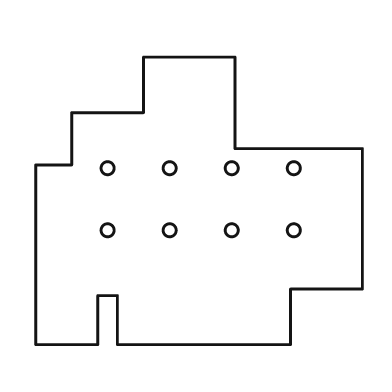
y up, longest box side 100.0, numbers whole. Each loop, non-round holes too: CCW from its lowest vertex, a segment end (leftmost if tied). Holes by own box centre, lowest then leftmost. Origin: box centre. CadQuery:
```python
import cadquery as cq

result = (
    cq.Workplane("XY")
    .moveTo(-50.0, -44.0)
    .lineTo(-31.0, -44.0)
    .lineTo(-31.0, -29.0)
    .lineTo(-25.0, -29.0)
    .lineTo(-25.0, -44.0)
    .lineTo(28.0, -44.0)
    .lineTo(28.0, -27.0)
    .lineTo(50.0, -27.0)
    .lineTo(50.0, 16.0)
    .lineTo(11.0, 16.0)
    .lineTo(11.0, 44.0)
    .lineTo(-17.0, 44.0)
    .lineTo(-17.0, 27.0)
    .lineTo(-39.0, 27.0)
    .lineTo(-39.0, 11.0)
    .lineTo(-50.0, 11.0)
    .close()
    .moveTo(-28.0, -9.0)
    .circle(2.0)
    .moveTo(-9.0, -9.0)
    .circle(2.0)
    .moveTo(10.0, -9.0)
    .circle(2.0)
    .moveTo(29.0, -9.0)
    .circle(2.0)
    .moveTo(-28.0, 10.0)
    .circle(2.0)
    .moveTo(-9.0, 10.0)
    .circle(2.0)
    .moveTo(10.0, 10.0)
    .circle(2.0)
    .moveTo(29.0, 10.0)
    .circle(2.0)
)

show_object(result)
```